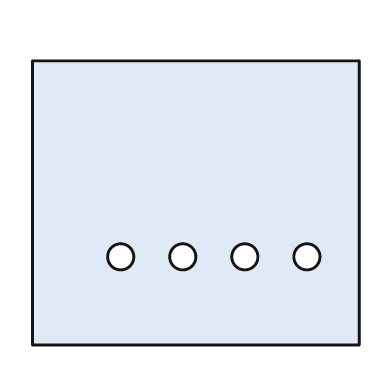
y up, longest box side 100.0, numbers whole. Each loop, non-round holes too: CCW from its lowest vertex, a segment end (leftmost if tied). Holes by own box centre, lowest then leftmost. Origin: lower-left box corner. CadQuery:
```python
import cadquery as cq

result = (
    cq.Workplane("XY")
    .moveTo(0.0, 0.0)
    .lineTo(100.0, 0.0)
    .lineTo(100.0, 87.0)
    .lineTo(0.0, 87.0)
    .close()
    .moveTo(27.0, 27.0)
    .circle(4.0)
    .moveTo(46.0, 27.0)
    .circle(4.0)
    .moveTo(65.0, 27.0)
    .circle(4.0)
    .moveTo(84.0, 27.0)
    .circle(4.0)
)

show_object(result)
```